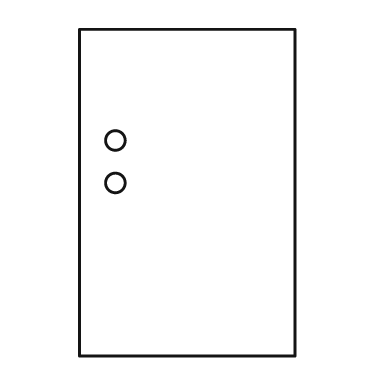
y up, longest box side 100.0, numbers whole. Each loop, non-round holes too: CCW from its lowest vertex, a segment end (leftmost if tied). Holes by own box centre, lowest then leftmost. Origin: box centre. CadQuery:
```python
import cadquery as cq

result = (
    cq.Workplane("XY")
    .moveTo(-33.0, -50.0)
    .lineTo(33.0, -50.0)
    .lineTo(33.0, 50.0)
    .lineTo(-33.0, 50.0)
    .close()
    .moveTo(-22.0, 3.0)
    .circle(3.0)
    .moveTo(-22.0, 16.0)
    .circle(3.0)
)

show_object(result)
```